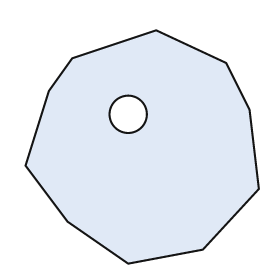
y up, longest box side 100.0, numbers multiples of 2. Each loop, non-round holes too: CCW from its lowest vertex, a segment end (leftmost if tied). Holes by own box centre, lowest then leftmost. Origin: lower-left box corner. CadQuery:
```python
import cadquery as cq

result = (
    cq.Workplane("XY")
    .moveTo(44.0, 0.0)
    .lineTo(76.0, 6.0)
    .lineTo(100.0, 32.0)
    .lineTo(96.0, 66.0)
    .lineTo(86.0, 86.0)
    .lineTo(56.0, 100.0)
    .lineTo(20.0, 88.0)
    .lineTo(10.0, 74.0)
    .lineTo(0.0, 42.0)
    .lineTo(18.0, 18.0)
    .close()
    .moveTo(44.0, 64.0)
    .circle(8.0)
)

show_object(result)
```